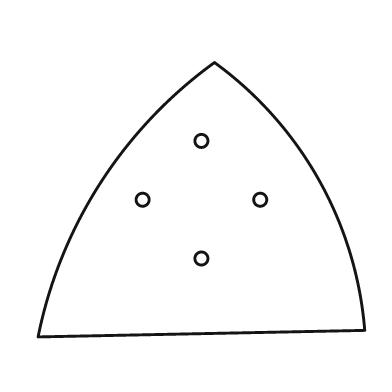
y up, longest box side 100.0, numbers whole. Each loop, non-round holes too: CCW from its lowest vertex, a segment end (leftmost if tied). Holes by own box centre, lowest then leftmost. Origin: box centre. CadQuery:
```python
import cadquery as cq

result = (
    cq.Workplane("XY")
    .moveTo(-50.0, -42.0)
    .lineTo(50.0, -40.0)
    .threePointArc((36.0, 6.0), (4.0, 42.0))
    .threePointArc((-31.0, 5.0), (-50.0, -42.0))
    .close()
    .moveTo(0.0, -18.0)
    .circle(2.0)
    .moveTo(-18.0, 0.0)
    .circle(2.0)
    .moveTo(18.0, 0.0)
    .circle(2.0)
    .moveTo(0.0, 18.0)
    .circle(2.0)
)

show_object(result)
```